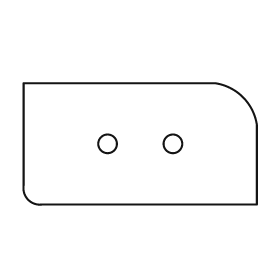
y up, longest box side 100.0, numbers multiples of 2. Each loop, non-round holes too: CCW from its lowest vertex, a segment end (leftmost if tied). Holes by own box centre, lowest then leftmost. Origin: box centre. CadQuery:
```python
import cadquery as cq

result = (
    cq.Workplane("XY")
    .moveTo(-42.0, -26.0)
    .lineTo(50.0, -26.0)
    .lineTo(50.0, 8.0)
    .threePointArc((44.0, 20.0), (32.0, 26.0))
    .lineTo(-50.0, 26.0)
    .lineTo(-50.0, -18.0)
    .threePointArc((-48.0, -24.0), (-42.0, -26.0))
    .close()
    .moveTo(-14.0, 0.0)
    .circle(4.0)
    .moveTo(14.0, 0.0)
    .circle(4.0)
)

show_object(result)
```